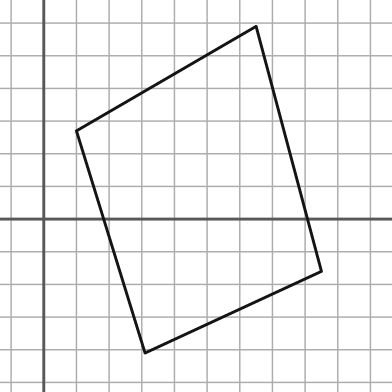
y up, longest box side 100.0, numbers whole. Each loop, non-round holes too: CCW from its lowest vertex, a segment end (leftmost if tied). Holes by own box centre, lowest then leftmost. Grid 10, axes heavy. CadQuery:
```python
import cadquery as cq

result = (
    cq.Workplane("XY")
    .moveTo(31.0, -41.0)
    .lineTo(85.0, -16.0)
    .lineTo(65.0, 59.0)
    .lineTo(10.0, 27.0)
    .close()
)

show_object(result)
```